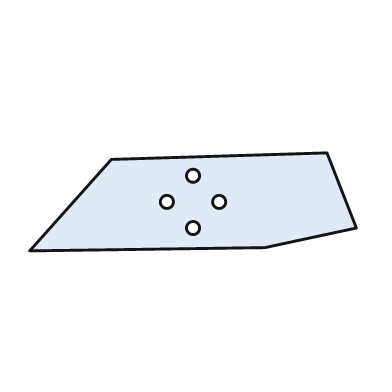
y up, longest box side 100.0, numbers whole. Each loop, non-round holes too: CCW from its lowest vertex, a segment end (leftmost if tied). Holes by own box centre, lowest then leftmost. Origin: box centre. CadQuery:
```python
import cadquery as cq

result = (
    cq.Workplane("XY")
    .moveTo(-50.0, -15.0)
    .lineTo(22.0, -14.0)
    .lineTo(50.0, -8.0)
    .lineTo(41.0, 15.0)
    .lineTo(-25.0, 13.0)
    .close()
    .moveTo(0.0, -8.0)
    .circle(2.0)
    .moveTo(-8.0, 0.0)
    .circle(2.0)
    .moveTo(8.0, 0.0)
    .circle(2.0)
    .moveTo(0.0, 8.0)
    .circle(2.0)
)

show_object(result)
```